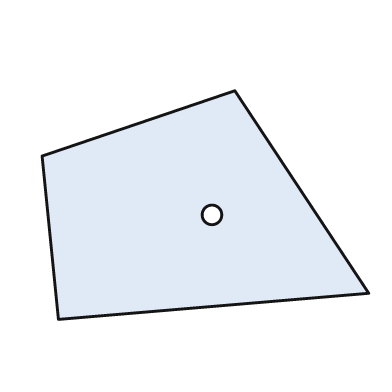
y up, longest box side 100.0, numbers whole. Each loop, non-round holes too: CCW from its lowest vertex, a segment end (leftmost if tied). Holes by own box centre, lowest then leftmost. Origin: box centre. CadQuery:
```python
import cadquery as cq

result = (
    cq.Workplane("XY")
    .moveTo(-45.0, -35.0)
    .lineTo(50.0, -27.0)
    .lineTo(9.0, 35.0)
    .lineTo(-50.0, 15.0)
    .close()
    .moveTo(2.0, -3.0)
    .circle(3.0)
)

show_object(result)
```